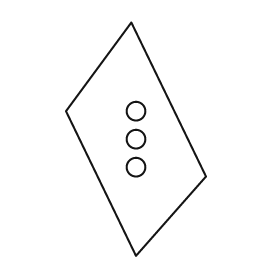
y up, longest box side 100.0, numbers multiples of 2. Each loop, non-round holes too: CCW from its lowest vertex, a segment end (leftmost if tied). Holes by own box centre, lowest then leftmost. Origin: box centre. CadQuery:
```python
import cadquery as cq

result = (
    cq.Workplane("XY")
    .moveTo(0.0, -50.0)
    .lineTo(30.0, -16.0)
    .lineTo(-2.0, 50.0)
    .lineTo(-30.0, 12.0)
    .close()
    .moveTo(0.0, -12.0)
    .circle(4.0)
    .moveTo(0.0, 0.0)
    .circle(4.0)
    .moveTo(0.0, 12.0)
    .circle(4.0)
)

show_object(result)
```